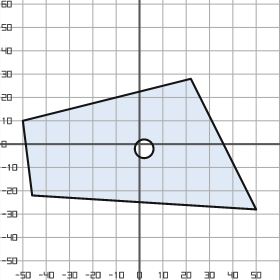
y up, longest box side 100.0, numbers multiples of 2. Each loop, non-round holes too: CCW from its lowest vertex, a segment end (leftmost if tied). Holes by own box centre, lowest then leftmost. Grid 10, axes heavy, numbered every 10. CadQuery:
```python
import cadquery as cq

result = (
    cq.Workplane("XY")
    .moveTo(50.0, -28.0)
    .lineTo(22.0, 28.0)
    .lineTo(-50.0, 10.0)
    .lineTo(-46.0, -22.0)
    .close()
    .moveTo(2.0, -2.0)
    .circle(4.0)
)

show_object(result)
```